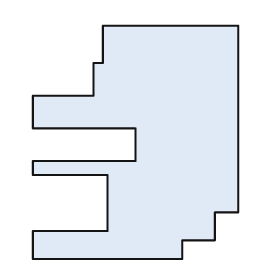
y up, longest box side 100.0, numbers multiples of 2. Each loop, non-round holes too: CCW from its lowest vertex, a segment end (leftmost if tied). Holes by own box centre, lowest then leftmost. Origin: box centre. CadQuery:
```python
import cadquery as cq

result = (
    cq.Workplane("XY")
    .moveTo(-44.0, -50.0)
    .lineTo(20.0, -50.0)
    .lineTo(20.0, -42.0)
    .lineTo(34.0, -42.0)
    .lineTo(34.0, -30.0)
    .lineTo(44.0, -30.0)
    .lineTo(44.0, 50.0)
    .lineTo(-14.0, 50.0)
    .lineTo(-14.0, 34.0)
    .lineTo(-18.0, 34.0)
    .lineTo(-18.0, 20.0)
    .lineTo(-44.0, 20.0)
    .lineTo(-44.0, 6.0)
    .lineTo(0.0, 6.0)
    .lineTo(0.0, -8.0)
    .lineTo(-44.0, -8.0)
    .lineTo(-44.0, -14.0)
    .lineTo(-12.0, -14.0)
    .lineTo(-12.0, -38.0)
    .lineTo(-44.0, -38.0)
    .close()
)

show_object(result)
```